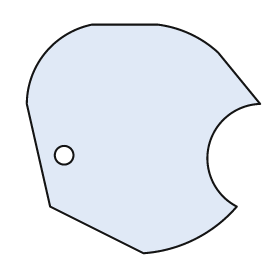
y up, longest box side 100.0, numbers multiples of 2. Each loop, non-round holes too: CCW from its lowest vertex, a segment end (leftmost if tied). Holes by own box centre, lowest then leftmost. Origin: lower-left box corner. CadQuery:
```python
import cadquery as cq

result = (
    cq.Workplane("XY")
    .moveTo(50.0, 0.0)
    .threePointArc((72.0, 6.0), (90.0, 20.0))
    .threePointArc((78.0, 46.0), (100.0, 64.0))
    .lineTo(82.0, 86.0)
    .threePointArc((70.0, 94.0), (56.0, 98.0))
    .lineTo(28.0, 98.0)
    .threePointArc((8.0, 86.0), (0.0, 64.0))
    .lineTo(10.0, 20.0)
    .close()
    .moveTo(16.0, 42.0)
    .circle(4.0)
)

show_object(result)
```